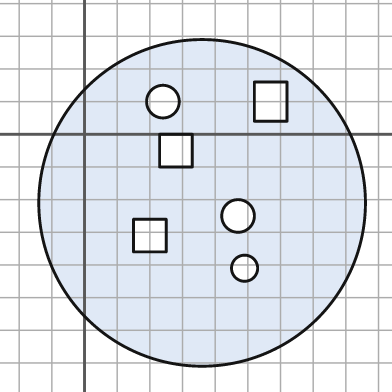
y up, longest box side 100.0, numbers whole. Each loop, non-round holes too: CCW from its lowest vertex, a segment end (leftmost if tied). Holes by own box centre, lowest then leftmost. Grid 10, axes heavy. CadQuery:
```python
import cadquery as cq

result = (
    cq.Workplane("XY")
    .moveTo(36.0, -21.0)
    .circle(50.0)
    .moveTo(49.0, -41.0)
    .circle(4.0)
    .moveTo(15.0, -36.0)
    .lineTo(25.0, -36.0)
    .lineTo(25.0, -26.0)
    .lineTo(15.0, -26.0)
    .close()
    .moveTo(47.0, -25.0)
    .circle(5.0)
    .moveTo(23.0, -10.0)
    .lineTo(33.0, -10.0)
    .lineTo(33.0, 0.0)
    .lineTo(23.0, 0.0)
    .close()
    .moveTo(24.0, 10.0)
    .circle(5.0)
    .moveTo(52.0, 4.0)
    .lineTo(62.0, 4.0)
    .lineTo(62.0, 16.0)
    .lineTo(52.0, 16.0)
    .close()
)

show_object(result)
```